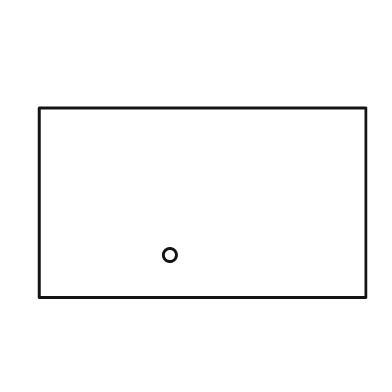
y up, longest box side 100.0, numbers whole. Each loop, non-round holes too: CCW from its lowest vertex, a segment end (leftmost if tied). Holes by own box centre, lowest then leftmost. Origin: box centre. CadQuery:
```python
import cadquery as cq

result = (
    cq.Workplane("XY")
    .moveTo(-50.0, -29.0)
    .lineTo(50.0, -29.0)
    .lineTo(50.0, 29.0)
    .lineTo(-50.0, 29.0)
    .close()
    .moveTo(-10.0, -16.0)
    .circle(2.0)
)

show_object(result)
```